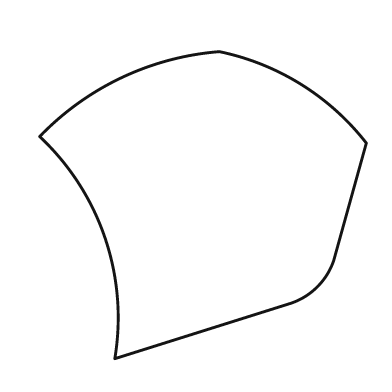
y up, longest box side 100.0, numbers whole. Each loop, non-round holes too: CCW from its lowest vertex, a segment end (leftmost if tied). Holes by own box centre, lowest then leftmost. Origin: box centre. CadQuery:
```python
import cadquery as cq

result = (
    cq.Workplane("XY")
    .moveTo(-27.0, -47.0)
    .lineTo(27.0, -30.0)
    .threePointArc((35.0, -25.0), (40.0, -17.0))
    .lineTo(50.0, 19.0)
    .threePointArc((30.0, 37.0), (5.0, 47.0))
    .threePointArc((-25.0, 39.0), (-50.0, 21.0))
    .threePointArc((-30.0, -10.0), (-27.0, -47.0))
    .close()
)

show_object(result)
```